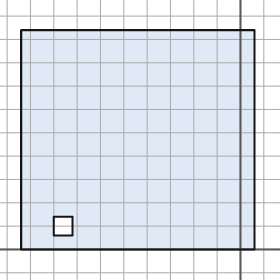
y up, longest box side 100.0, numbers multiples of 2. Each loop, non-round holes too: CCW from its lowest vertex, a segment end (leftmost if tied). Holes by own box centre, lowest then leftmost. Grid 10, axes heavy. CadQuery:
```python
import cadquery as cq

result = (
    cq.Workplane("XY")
    .moveTo(-94.0, 0.0)
    .lineTo(6.0, 0.0)
    .lineTo(6.0, 94.0)
    .lineTo(-94.0, 94.0)
    .close()
    .moveTo(-80.0, 6.0)
    .lineTo(-72.0, 6.0)
    .lineTo(-72.0, 14.0)
    .lineTo(-80.0, 14.0)
    .close()
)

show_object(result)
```